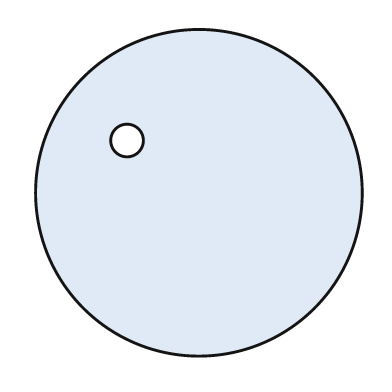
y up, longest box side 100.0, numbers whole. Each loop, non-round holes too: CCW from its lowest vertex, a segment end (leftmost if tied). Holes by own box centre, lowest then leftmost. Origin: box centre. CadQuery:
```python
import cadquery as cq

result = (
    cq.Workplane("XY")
    .moveTo(0.0, 0.0)
    .circle(50.0)
    .moveTo(-22.0, 16.0)
    .circle(5.0)
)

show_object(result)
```